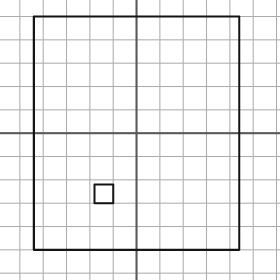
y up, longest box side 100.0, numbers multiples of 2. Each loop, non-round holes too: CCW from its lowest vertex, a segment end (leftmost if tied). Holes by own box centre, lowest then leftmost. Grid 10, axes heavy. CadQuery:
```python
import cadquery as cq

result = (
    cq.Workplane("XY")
    .moveTo(-44.0, -50.0)
    .lineTo(44.0, -50.0)
    .lineTo(44.0, 50.0)
    .lineTo(-44.0, 50.0)
    .close()
    .moveTo(-18.0, -30.0)
    .lineTo(-10.0, -30.0)
    .lineTo(-10.0, -22.0)
    .lineTo(-18.0, -22.0)
    .close()
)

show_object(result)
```